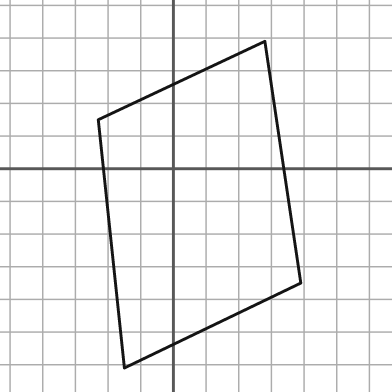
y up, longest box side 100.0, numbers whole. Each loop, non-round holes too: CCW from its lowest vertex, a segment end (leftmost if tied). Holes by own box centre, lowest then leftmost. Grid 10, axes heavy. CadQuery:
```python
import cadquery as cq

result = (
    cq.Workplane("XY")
    .moveTo(-15.0, -61.0)
    .lineTo(39.0, -35.0)
    .lineTo(28.0, 39.0)
    .lineTo(-23.0, 15.0)
    .close()
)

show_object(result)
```